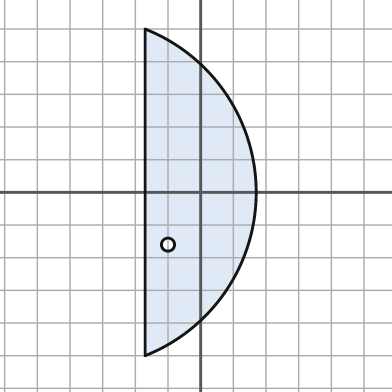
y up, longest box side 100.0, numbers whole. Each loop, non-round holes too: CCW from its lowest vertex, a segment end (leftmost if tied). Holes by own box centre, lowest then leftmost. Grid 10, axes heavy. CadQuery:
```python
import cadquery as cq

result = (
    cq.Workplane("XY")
    .moveTo(-17.0, -50.0)
    .threePointArc((17.0, 0.0), (-17.0, 50.0))
    .close()
    .moveTo(-10.0, -16.0)
    .circle(2.0)
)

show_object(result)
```